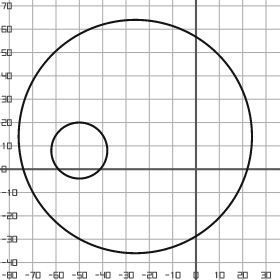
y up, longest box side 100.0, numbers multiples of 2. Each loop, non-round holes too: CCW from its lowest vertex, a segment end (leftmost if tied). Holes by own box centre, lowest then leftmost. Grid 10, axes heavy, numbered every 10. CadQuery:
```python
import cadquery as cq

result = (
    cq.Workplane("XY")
    .moveTo(-26.0, 14.0)
    .circle(50.0)
    .moveTo(-50.0, 8.0)
    .circle(12.0)
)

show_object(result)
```